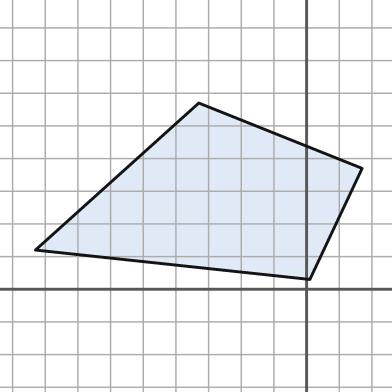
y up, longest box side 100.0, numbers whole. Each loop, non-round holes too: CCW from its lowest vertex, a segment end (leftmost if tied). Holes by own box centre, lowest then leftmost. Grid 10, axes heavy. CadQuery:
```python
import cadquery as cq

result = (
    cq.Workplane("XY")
    .moveTo(1.0, 3.0)
    .lineTo(17.0, 37.0)
    .lineTo(-33.0, 57.0)
    .lineTo(-83.0, 12.0)
    .close()
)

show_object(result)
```